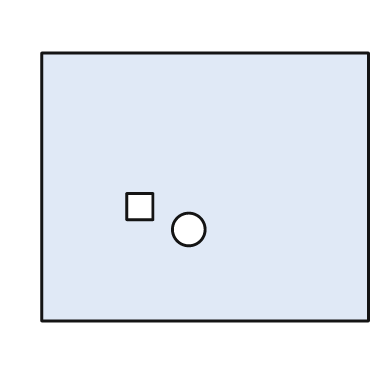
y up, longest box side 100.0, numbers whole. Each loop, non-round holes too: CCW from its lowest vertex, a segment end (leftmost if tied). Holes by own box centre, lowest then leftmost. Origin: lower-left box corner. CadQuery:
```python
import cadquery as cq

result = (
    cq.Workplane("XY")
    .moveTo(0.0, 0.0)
    .lineTo(100.0, 0.0)
    .lineTo(100.0, 82.0)
    .lineTo(0.0, 82.0)
    .close()
    .moveTo(45.0, 28.0)
    .circle(5.0)
    .moveTo(26.0, 31.0)
    .lineTo(34.0, 31.0)
    .lineTo(34.0, 39.0)
    .lineTo(26.0, 39.0)
    .close()
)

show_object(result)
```